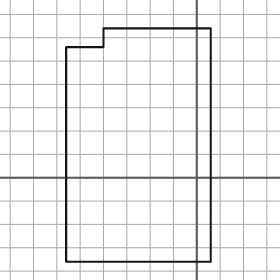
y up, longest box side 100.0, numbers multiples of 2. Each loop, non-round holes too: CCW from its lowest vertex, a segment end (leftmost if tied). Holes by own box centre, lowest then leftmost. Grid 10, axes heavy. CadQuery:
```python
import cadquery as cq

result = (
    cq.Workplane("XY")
    .moveTo(-56.0, -36.0)
    .lineTo(6.0, -36.0)
    .lineTo(6.0, 64.0)
    .lineTo(-40.0, 64.0)
    .lineTo(-40.0, 56.0)
    .lineTo(-56.0, 56.0)
    .close()
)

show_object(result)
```